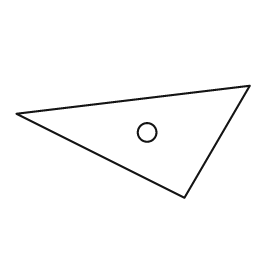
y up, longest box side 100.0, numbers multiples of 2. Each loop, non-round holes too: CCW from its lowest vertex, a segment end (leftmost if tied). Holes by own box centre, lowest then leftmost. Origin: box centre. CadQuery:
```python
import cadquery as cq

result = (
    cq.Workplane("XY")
    .moveTo(22.0, -24.0)
    .lineTo(50.0, 24.0)
    .lineTo(-50.0, 12.0)
    .close()
    .moveTo(6.0, 4.0)
    .circle(4.0)
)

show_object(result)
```